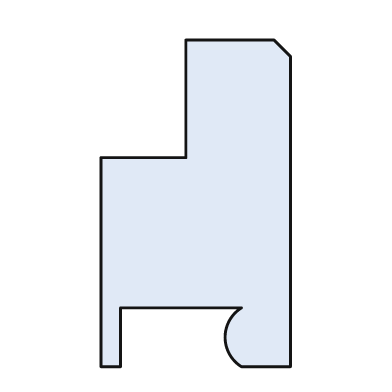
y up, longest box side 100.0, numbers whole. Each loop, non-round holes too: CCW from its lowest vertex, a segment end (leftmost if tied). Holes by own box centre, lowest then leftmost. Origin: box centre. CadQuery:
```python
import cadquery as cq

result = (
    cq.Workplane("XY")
    .moveTo(-29.0, -50.0)
    .lineTo(-23.0, -50.0)
    .lineTo(-23.0, -32.0)
    .lineTo(14.0, -32.0)
    .threePointArc((9.0, -41.0), (14.0, -50.0))
    .lineTo(29.0, -50.0)
    .lineTo(29.0, 45.0)
    .lineTo(24.0, 50.0)
    .lineTo(-3.0, 50.0)
    .lineTo(-3.0, 14.0)
    .lineTo(-29.0, 14.0)
    .close()
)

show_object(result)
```